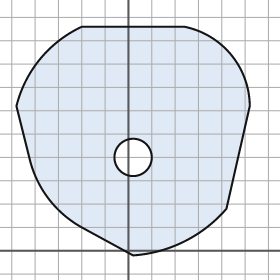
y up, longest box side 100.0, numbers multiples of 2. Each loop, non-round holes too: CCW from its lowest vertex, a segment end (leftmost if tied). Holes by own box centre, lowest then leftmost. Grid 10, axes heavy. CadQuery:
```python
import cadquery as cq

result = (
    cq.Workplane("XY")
    .moveTo(2.0, -2.0)
    .threePointArc((24.0, 4.0), (42.0, 18.0))
    .lineTo(52.0, 62.0)
    .threePointArc((44.0, 84.0), (24.0, 96.0))
    .lineTo(-20.0, 96.0)
    .threePointArc((-38.0, 82.0), (-48.0, 62.0))
    .lineTo(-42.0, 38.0)
    .threePointArc((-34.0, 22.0), (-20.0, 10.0))
    .close()
    .moveTo(2.0, 40.0)
    .circle(8.0)
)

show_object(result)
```